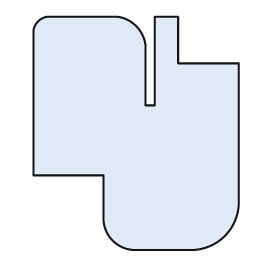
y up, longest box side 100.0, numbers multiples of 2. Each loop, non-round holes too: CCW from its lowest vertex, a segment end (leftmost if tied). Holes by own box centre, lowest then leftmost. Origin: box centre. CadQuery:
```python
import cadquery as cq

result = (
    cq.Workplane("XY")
    .moveTo(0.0, -50.0)
    .lineTo(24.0, -50.0)
    .threePointArc((38.0, -44.0), (44.0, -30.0))
    .lineTo(44.0, 30.0)
    .lineTo(18.0, 30.0)
    .lineTo(18.0, 50.0)
    .lineTo(8.0, 50.0)
    .lineTo(8.0, 12.0)
    .lineTo(4.0, 12.0)
    .lineTo(4.0, 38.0)
    .threePointArc((0.0, 46.0), (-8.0, 50.0))
    .lineTo(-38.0, 50.0)
    .threePointArc((-42.0, 48.0), (-44.0, 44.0))
    .lineTo(-44.0, -18.0)
    .lineTo(-14.0, -18.0)
    .lineTo(-14.0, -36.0)
    .threePointArc((-10.0, -46.0), (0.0, -50.0))
    .close()
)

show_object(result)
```